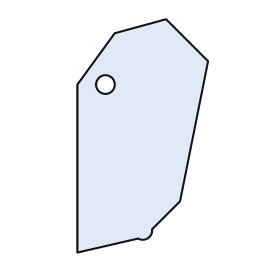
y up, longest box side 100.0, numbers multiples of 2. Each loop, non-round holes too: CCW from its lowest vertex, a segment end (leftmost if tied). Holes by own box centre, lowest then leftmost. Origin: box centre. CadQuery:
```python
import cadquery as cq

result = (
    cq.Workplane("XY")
    .moveTo(-28.0, -50.0)
    .lineTo(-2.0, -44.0)
    .threePointArc((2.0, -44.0), (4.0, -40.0))
    .lineTo(16.0, -28.0)
    .lineTo(28.0, 32.0)
    .lineTo(10.0, 50.0)
    .lineTo(-12.0, 44.0)
    .lineTo(-28.0, 22.0)
    .close()
    .moveTo(-16.0, 22.0)
    .circle(4.0)
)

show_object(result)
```